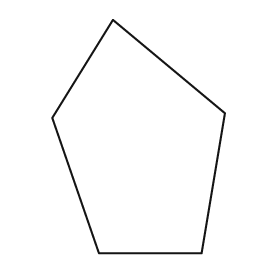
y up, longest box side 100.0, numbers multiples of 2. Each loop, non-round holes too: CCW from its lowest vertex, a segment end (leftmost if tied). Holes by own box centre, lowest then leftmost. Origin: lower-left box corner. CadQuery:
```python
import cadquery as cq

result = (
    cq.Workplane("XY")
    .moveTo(20.0, 0.0)
    .lineTo(64.0, 0.0)
    .lineTo(74.0, 60.0)
    .lineTo(26.0, 100.0)
    .lineTo(0.0, 58.0)
    .close()
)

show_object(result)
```